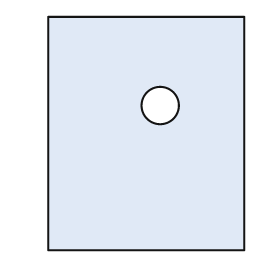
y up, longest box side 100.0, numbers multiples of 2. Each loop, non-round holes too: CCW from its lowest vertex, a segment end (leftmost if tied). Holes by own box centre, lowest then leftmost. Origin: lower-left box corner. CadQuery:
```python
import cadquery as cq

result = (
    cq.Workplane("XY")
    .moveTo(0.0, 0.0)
    .lineTo(84.0, 0.0)
    .lineTo(84.0, 100.0)
    .lineTo(0.0, 100.0)
    .close()
    .moveTo(48.0, 62.0)
    .circle(8.0)
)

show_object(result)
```